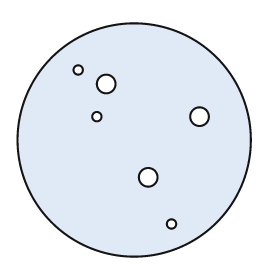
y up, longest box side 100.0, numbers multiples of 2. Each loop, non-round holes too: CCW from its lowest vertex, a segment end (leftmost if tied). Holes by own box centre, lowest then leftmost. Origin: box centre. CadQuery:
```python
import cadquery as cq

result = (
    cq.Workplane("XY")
    .moveTo(0.0, 0.0)
    .circle(50.0)
    .moveTo(16.0, -36.0)
    .circle(2.0)
    .moveTo(6.0, -16.0)
    .circle(4.0)
    .moveTo(-16.0, 10.0)
    .circle(2.0)
    .moveTo(28.0, 10.0)
    .circle(4.0)
    .moveTo(-12.0, 24.0)
    .circle(4.0)
    .moveTo(-24.0, 30.0)
    .circle(2.0)
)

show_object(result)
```